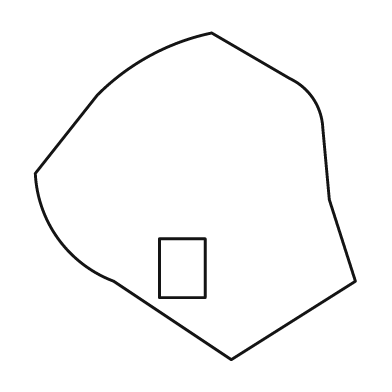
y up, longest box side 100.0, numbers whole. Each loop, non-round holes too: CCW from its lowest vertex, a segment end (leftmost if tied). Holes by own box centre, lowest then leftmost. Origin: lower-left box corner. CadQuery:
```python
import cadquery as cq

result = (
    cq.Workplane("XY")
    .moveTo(60.0, 0.0)
    .lineTo(98.0, 24.0)
    .lineTo(90.0, 49.0)
    .lineTo(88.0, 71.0)
    .threePointArc((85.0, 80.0), (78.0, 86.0))
    .lineTo(54.0, 100.0)
    .threePointArc((35.0, 93.0), (19.0, 81.0))
    .lineTo(0.0, 57.0)
    .threePointArc((7.0, 37.0), (24.0, 24.0))
    .close()
    .moveTo(38.0, 19.0)
    .lineTo(52.0, 19.0)
    .lineTo(52.0, 37.0)
    .lineTo(38.0, 37.0)
    .close()
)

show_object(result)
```